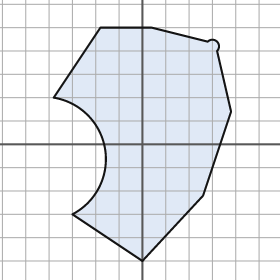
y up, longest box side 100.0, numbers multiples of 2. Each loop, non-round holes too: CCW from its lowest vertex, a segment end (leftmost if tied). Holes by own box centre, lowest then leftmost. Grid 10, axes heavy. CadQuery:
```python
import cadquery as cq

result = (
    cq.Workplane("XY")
    .moveTo(0.0, -50.0)
    .lineTo(26.0, -22.0)
    .lineTo(38.0, 14.0)
    .lineTo(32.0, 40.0)
    .threePointArc((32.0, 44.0), (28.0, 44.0))
    .lineTo(4.0, 50.0)
    .lineTo(-18.0, 50.0)
    .lineTo(-38.0, 20.0)
    .threePointArc((-16.0, -2.0), (-30.0, -30.0))
    .close()
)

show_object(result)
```